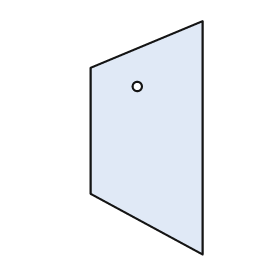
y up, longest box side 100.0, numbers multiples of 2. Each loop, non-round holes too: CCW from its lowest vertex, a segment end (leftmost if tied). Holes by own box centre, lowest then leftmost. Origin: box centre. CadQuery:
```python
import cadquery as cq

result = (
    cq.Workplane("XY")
    .moveTo(24.0, -50.0)
    .lineTo(24.0, 50.0)
    .lineTo(-24.0, 30.0)
    .lineTo(-24.0, -24.0)
    .close()
    .moveTo(-4.0, 22.0)
    .circle(2.0)
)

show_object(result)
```